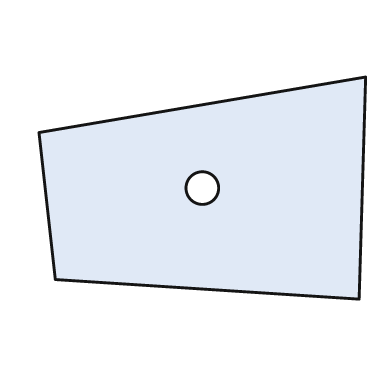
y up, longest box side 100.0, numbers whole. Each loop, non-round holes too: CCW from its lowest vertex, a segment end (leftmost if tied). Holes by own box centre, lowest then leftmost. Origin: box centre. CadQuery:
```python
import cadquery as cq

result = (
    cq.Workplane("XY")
    .moveTo(48.0, -34.0)
    .lineTo(50.0, 34.0)
    .lineTo(-50.0, 17.0)
    .lineTo(-45.0, -28.0)
    .close()
    .moveTo(0.0, 0.0)
    .circle(5.0)
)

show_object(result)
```